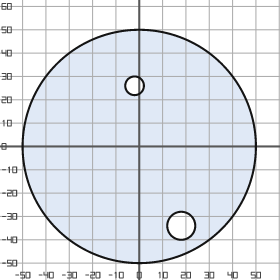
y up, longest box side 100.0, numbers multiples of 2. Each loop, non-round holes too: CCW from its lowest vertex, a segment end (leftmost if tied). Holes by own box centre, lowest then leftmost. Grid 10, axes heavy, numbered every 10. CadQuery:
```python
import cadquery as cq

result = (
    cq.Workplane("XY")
    .moveTo(0.0, 0.0)
    .circle(50.0)
    .moveTo(18.0, -34.0)
    .circle(6.0)
    .moveTo(-2.0, 26.0)
    .circle(4.0)
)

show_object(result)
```